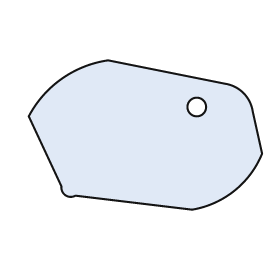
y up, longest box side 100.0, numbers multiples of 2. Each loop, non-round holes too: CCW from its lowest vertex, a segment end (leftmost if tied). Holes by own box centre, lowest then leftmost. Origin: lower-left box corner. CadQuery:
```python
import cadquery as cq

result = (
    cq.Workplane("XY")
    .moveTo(70.0, 0.0)
    .threePointArc((88.0, 8.0), (100.0, 24.0))
    .lineTo(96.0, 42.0)
    .threePointArc((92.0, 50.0), (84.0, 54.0))
    .lineTo(34.0, 64.0)
    .threePointArc((14.0, 56.0), (0.0, 40.0))
    .lineTo(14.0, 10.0)
    .threePointArc((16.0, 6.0), (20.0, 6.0))
    .close()
    .moveTo(72.0, 44.0)
    .circle(4.0)
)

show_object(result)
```